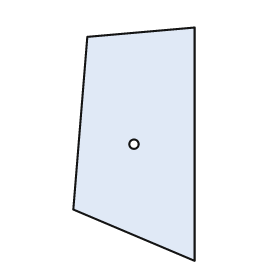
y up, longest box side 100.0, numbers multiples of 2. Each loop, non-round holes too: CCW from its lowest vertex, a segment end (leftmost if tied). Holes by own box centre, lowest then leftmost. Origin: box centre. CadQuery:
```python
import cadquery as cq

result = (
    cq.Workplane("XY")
    .moveTo(26.0, -50.0)
    .lineTo(26.0, 50.0)
    .lineTo(-20.0, 46.0)
    .lineTo(-26.0, -28.0)
    .close()
    .moveTo(0.0, 0.0)
    .circle(2.0)
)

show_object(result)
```